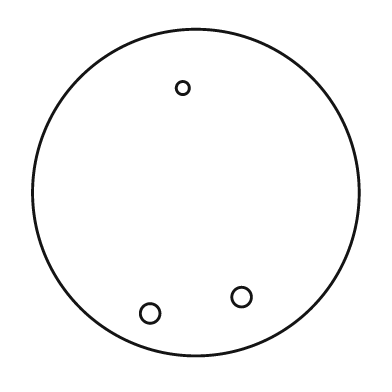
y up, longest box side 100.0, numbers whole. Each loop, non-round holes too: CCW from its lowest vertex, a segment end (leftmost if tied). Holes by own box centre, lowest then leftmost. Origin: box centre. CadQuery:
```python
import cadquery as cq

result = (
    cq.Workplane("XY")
    .moveTo(0.0, 0.0)
    .circle(50.0)
    .moveTo(-14.0, -37.0)
    .circle(3.0)
    .moveTo(14.0, -32.0)
    .circle(3.0)
    .moveTo(-4.0, 32.0)
    .circle(2.0)
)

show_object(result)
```